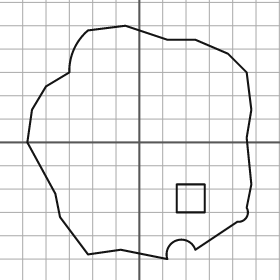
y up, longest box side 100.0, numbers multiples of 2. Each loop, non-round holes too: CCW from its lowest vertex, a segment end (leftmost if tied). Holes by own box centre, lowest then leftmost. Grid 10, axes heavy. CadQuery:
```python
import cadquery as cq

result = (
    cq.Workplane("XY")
    .moveTo(12.0, -50.0)
    .threePointArc((16.0, -42.0), (24.0, -46.0))
    .lineTo(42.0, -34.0)
    .threePointArc((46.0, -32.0), (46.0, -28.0))
    .lineTo(48.0, -18.0)
    .lineTo(46.0, 2.0)
    .lineTo(48.0, 14.0)
    .lineTo(46.0, 30.0)
    .lineTo(38.0, 38.0)
    .lineTo(24.0, 44.0)
    .lineTo(12.0, 44.0)
    .lineTo(-6.0, 50.0)
    .lineTo(-22.0, 48.0)
    .threePointArc((-28.0, 40.0), (-30.0, 30.0))
    .lineTo(-40.0, 24.0)
    .lineTo(-46.0, 14.0)
    .lineTo(-48.0, 0.0)
    .lineTo(-36.0, -22.0)
    .lineTo(-34.0, -32.0)
    .lineTo(-22.0, -48.0)
    .lineTo(-8.0, -46.0)
    .close()
    .moveTo(16.0, -30.0)
    .lineTo(28.0, -30.0)
    .lineTo(28.0, -18.0)
    .lineTo(16.0, -18.0)
    .close()
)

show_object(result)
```